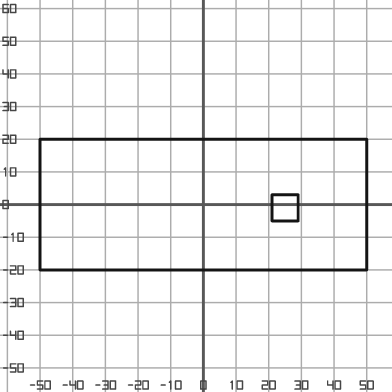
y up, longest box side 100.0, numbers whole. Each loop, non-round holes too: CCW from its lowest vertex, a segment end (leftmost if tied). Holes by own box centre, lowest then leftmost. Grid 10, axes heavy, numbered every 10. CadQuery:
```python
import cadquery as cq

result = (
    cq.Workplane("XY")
    .moveTo(-50.0, -20.0)
    .lineTo(50.0, -20.0)
    .lineTo(50.0, 20.0)
    .lineTo(-50.0, 20.0)
    .close()
    .moveTo(21.0, -5.0)
    .lineTo(29.0, -5.0)
    .lineTo(29.0, 3.0)
    .lineTo(21.0, 3.0)
    .close()
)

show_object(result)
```